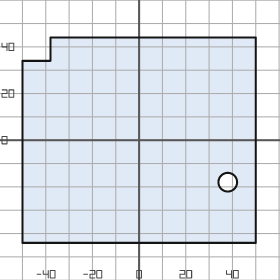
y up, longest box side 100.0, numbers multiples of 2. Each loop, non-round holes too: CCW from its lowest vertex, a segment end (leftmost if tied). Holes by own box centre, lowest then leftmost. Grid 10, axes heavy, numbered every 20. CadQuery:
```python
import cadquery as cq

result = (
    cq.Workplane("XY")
    .moveTo(-50.0, -44.0)
    .lineTo(50.0, -44.0)
    .lineTo(50.0, 44.0)
    .lineTo(-38.0, 44.0)
    .lineTo(-38.0, 34.0)
    .lineTo(-50.0, 34.0)
    .close()
    .moveTo(38.0, -18.0)
    .circle(4.0)
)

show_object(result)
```